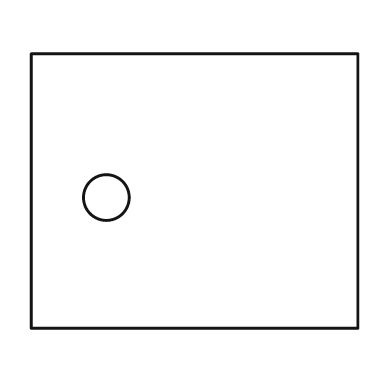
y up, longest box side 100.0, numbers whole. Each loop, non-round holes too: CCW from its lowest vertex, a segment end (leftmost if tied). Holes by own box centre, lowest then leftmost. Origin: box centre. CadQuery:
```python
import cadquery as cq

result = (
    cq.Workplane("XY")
    .moveTo(-50.0, -42.0)
    .lineTo(50.0, -42.0)
    .lineTo(50.0, 42.0)
    .lineTo(-50.0, 42.0)
    .close()
    .moveTo(-27.0, -2.0)
    .circle(7.0)
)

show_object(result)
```